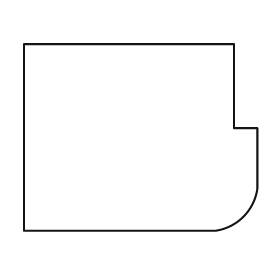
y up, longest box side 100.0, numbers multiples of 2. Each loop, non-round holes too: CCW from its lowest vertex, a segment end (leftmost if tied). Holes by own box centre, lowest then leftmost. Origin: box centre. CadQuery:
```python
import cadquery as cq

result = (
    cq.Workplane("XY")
    .moveTo(-50.0, -40.0)
    .lineTo(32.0, -40.0)
    .threePointArc((44.0, -34.0), (50.0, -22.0))
    .lineTo(50.0, 4.0)
    .lineTo(40.0, 4.0)
    .lineTo(40.0, 40.0)
    .lineTo(-50.0, 40.0)
    .close()
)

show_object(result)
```